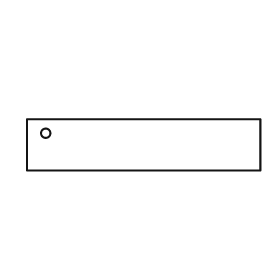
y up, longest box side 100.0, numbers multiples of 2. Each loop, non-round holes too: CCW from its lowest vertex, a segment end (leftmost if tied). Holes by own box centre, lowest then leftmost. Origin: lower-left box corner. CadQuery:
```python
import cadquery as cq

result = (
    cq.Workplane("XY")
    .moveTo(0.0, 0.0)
    .lineTo(100.0, 0.0)
    .lineTo(100.0, 22.0)
    .lineTo(0.0, 22.0)
    .close()
    .moveTo(8.0, 16.0)
    .circle(2.0)
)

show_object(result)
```